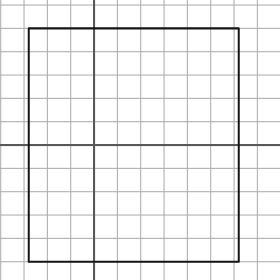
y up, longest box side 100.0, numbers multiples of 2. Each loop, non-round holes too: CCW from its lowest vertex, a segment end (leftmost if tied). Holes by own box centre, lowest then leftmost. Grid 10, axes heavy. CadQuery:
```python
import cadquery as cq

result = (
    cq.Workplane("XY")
    .moveTo(-28.0, -50.0)
    .lineTo(62.0, -50.0)
    .lineTo(62.0, 50.0)
    .lineTo(-28.0, 50.0)
    .close()
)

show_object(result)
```